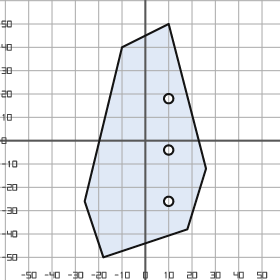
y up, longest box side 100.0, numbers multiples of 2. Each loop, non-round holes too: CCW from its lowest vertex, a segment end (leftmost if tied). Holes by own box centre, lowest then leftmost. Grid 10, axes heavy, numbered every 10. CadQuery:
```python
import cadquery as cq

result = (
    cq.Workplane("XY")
    .moveTo(-18.0, -50.0)
    .lineTo(18.0, -38.0)
    .lineTo(26.0, -12.0)
    .lineTo(10.0, 50.0)
    .lineTo(-10.0, 40.0)
    .lineTo(-26.0, -26.0)
    .close()
    .moveTo(10.0, -26.0)
    .circle(2.0)
    .moveTo(10.0, -4.0)
    .circle(2.0)
    .moveTo(10.0, 18.0)
    .circle(2.0)
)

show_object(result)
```